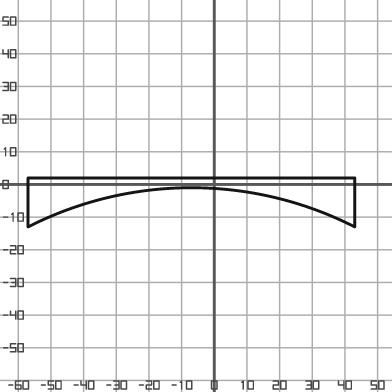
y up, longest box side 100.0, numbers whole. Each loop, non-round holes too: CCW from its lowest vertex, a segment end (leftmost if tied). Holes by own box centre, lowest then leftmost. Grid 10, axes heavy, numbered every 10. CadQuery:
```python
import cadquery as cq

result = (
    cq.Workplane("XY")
    .moveTo(-57.0, -13.0)
    .threePointArc((-7.0, -1.0), (43.0, -13.0))
    .lineTo(43.0, 2.0)
    .lineTo(-57.0, 2.0)
    .close()
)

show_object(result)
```